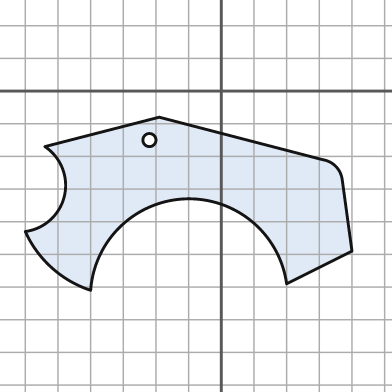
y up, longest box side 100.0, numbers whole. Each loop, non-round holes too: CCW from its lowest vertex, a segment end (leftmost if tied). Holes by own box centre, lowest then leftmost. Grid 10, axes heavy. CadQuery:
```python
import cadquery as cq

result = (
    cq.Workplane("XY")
    .moveTo(-40.0, -61.0)
    .threePointArc((-11.0, -33.0), (20.0, -59.0))
    .lineTo(40.0, -49.0)
    .lineTo(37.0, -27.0)
    .threePointArc((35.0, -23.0), (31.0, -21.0))
    .lineTo(-19.0, -8.0)
    .lineTo(-54.0, -17.0)
    .threePointArc((-48.0, -32.0), (-60.0, -43.0))
    .threePointArc((-52.0, -54.0), (-40.0, -61.0))
    .close()
    .moveTo(-22.0, -15.0)
    .circle(2.0)
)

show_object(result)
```